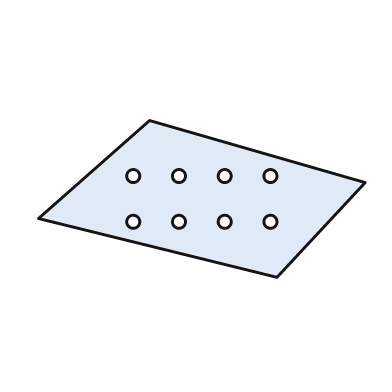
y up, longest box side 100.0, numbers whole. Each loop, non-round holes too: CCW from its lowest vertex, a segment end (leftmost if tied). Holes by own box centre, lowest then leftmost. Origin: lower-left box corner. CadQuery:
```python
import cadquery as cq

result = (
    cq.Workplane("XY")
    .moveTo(73.0, 0.0)
    .lineTo(100.0, 29.0)
    .lineTo(34.0, 48.0)
    .lineTo(0.0, 18.0)
    .close()
    .moveTo(29.0, 17.0)
    .circle(2.0)
    .moveTo(43.0, 17.0)
    .circle(2.0)
    .moveTo(57.0, 17.0)
    .circle(2.0)
    .moveTo(71.0, 17.0)
    .circle(2.0)
    .moveTo(29.0, 31.0)
    .circle(2.0)
    .moveTo(43.0, 31.0)
    .circle(2.0)
    .moveTo(57.0, 31.0)
    .circle(2.0)
    .moveTo(71.0, 31.0)
    .circle(2.0)
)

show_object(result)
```